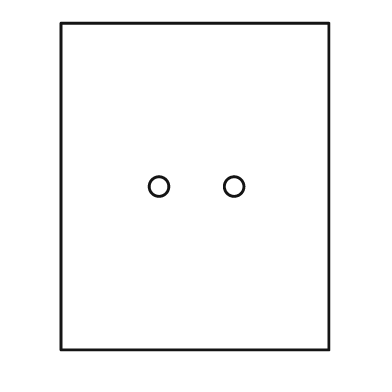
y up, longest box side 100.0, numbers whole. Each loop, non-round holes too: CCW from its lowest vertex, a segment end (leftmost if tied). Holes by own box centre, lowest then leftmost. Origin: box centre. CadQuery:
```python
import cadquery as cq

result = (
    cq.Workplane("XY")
    .moveTo(-41.0, -50.0)
    .lineTo(41.0, -50.0)
    .lineTo(41.0, 50.0)
    .lineTo(-41.0, 50.0)
    .close()
    .moveTo(-11.0, 0.0)
    .circle(3.0)
    .moveTo(12.0, 0.0)
    .circle(3.0)
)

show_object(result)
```